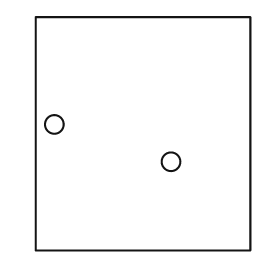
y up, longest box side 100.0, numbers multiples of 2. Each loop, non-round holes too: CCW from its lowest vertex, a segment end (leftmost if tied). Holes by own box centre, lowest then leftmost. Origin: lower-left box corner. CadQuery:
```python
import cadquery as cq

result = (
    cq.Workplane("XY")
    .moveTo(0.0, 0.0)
    .lineTo(92.0, 0.0)
    .lineTo(92.0, 100.0)
    .lineTo(0.0, 100.0)
    .close()
    .moveTo(58.0, 38.0)
    .circle(4.0)
    .moveTo(8.0, 54.0)
    .circle(4.0)
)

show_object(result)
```